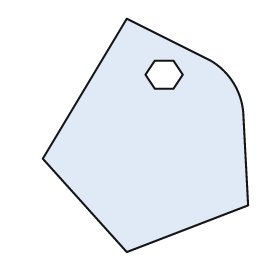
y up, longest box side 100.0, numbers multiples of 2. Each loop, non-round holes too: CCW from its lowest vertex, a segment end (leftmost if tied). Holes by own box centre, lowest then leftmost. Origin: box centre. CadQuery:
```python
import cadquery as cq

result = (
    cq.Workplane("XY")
    .moveTo(-8.0, -50.0)
    .lineTo(44.0, -30.0)
    .lineTo(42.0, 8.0)
    .threePointArc((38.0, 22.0), (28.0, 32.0))
    .lineTo(-8.0, 50.0)
    .lineTo(-44.0, -10.0)
    .close()
    .moveTo(4.0, 20.0)
    .lineTo(12.0, 20.0)
    .lineTo(16.0, 26.0)
    .lineTo(12.0, 32.0)
    .lineTo(4.0, 32.0)
    .lineTo(0.0, 26.0)
    .close()
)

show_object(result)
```